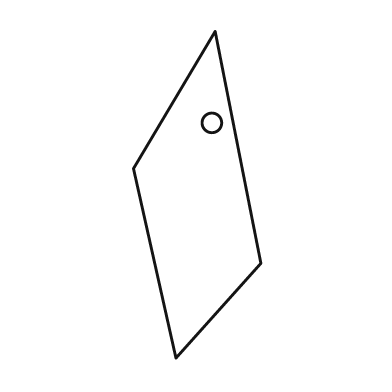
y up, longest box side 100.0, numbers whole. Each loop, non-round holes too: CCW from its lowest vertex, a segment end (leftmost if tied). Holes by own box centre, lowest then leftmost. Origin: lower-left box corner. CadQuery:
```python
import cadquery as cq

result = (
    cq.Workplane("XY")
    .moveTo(13.0, 0.0)
    .lineTo(39.0, 29.0)
    .lineTo(25.0, 100.0)
    .lineTo(0.0, 58.0)
    .close()
    .moveTo(24.0, 72.0)
    .circle(3.0)
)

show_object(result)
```